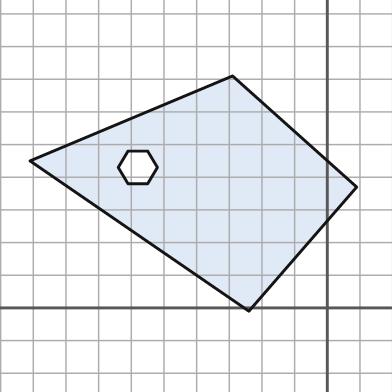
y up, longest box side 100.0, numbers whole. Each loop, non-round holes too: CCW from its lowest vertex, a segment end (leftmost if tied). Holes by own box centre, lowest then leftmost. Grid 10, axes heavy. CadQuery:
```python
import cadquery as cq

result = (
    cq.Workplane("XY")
    .moveTo(-24.0, -1.0)
    .lineTo(9.0, 37.0)
    .lineTo(-29.0, 71.0)
    .lineTo(-91.0, 45.0)
    .close()
    .moveTo(-61.0, 38.0)
    .lineTo(-55.0, 38.0)
    .lineTo(-52.0, 43.0)
    .lineTo(-55.0, 48.0)
    .lineTo(-61.0, 48.0)
    .lineTo(-64.0, 43.0)
    .close()
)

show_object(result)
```